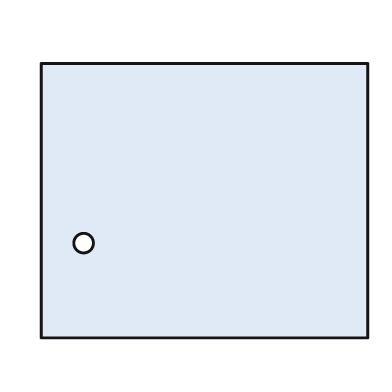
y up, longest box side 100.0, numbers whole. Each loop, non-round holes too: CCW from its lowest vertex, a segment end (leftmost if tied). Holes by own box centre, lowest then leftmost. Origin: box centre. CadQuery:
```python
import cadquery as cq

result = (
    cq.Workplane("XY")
    .moveTo(-50.0, -42.0)
    .lineTo(50.0, -42.0)
    .lineTo(50.0, 42.0)
    .lineTo(-50.0, 42.0)
    .close()
    .moveTo(-37.0, -13.0)
    .circle(3.0)
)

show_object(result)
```